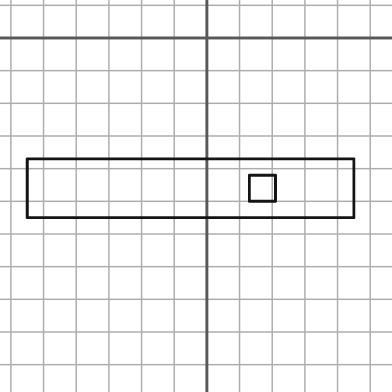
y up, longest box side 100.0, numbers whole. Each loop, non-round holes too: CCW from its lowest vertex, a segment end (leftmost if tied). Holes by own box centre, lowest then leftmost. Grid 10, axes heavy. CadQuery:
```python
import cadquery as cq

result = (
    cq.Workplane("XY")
    .moveTo(-55.0, -55.0)
    .lineTo(45.0, -55.0)
    .lineTo(45.0, -37.0)
    .lineTo(-55.0, -37.0)
    .close()
    .moveTo(13.0, -50.0)
    .lineTo(21.0, -50.0)
    .lineTo(21.0, -42.0)
    .lineTo(13.0, -42.0)
    .close()
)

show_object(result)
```